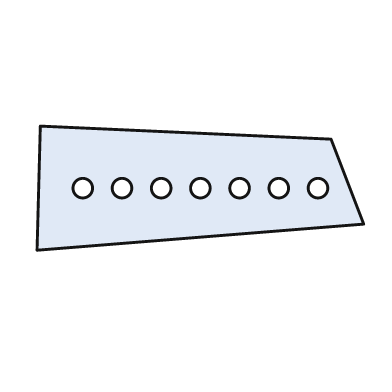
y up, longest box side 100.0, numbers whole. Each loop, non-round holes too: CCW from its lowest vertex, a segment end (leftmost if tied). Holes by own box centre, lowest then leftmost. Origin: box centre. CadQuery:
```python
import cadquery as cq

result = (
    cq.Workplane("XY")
    .moveTo(-50.0, -19.0)
    .lineTo(50.0, -11.0)
    .lineTo(40.0, 15.0)
    .lineTo(-49.0, 19.0)
    .close()
    .moveTo(-36.0, 0.0)
    .circle(3.0)
    .moveTo(-24.0, 0.0)
    .circle(3.0)
    .moveTo(-12.0, 0.0)
    .circle(3.0)
    .moveTo(0.0, 0.0)
    .circle(3.0)
    .moveTo(12.0, 0.0)
    .circle(3.0)
    .moveTo(24.0, 0.0)
    .circle(3.0)
    .moveTo(36.0, 0.0)
    .circle(3.0)
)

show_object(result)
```